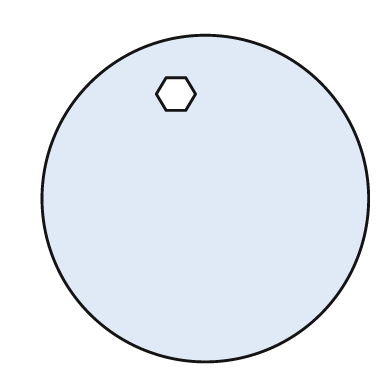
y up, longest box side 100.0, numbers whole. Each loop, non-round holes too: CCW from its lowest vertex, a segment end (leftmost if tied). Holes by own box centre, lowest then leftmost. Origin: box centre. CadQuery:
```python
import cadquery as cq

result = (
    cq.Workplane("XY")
    .moveTo(0.0, 0.0)
    .circle(50.0)
    .moveTo(-12.0, 27.0)
    .lineTo(-6.0, 27.0)
    .lineTo(-3.0, 32.0)
    .lineTo(-6.0, 37.0)
    .lineTo(-12.0, 37.0)
    .lineTo(-15.0, 32.0)
    .close()
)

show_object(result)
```